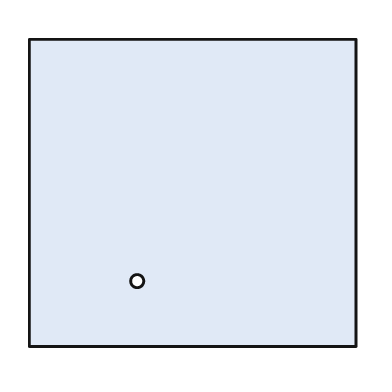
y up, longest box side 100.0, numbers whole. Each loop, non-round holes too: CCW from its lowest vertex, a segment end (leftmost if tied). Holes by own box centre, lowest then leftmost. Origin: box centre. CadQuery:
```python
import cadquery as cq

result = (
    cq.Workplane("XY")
    .moveTo(-50.0, -47.0)
    .lineTo(50.0, -47.0)
    .lineTo(50.0, 47.0)
    .lineTo(-50.0, 47.0)
    .close()
    .moveTo(-17.0, -27.0)
    .circle(2.0)
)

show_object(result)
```